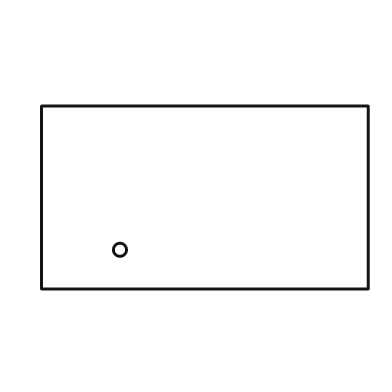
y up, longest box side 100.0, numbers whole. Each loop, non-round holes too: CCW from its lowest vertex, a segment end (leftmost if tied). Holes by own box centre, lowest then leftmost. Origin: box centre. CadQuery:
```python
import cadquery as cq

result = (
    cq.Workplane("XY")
    .moveTo(-50.0, -28.0)
    .lineTo(50.0, -28.0)
    .lineTo(50.0, 28.0)
    .lineTo(-50.0, 28.0)
    .close()
    .moveTo(-26.0, -16.0)
    .circle(2.0)
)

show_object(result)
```